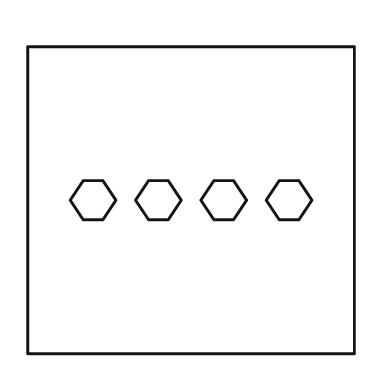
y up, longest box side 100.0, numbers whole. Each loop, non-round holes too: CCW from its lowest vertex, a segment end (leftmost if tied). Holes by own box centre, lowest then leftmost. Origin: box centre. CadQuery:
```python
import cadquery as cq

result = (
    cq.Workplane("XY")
    .moveTo(-50.0, -47.0)
    .lineTo(50.0, -47.0)
    .lineTo(50.0, 47.0)
    .lineTo(-50.0, 47.0)
    .close()
    .moveTo(-33.0, -6.0)
    .lineTo(-27.0, -6.0)
    .lineTo(-23.0, 0.0)
    .lineTo(-27.0, 6.0)
    .lineTo(-33.0, 6.0)
    .lineTo(-37.0, 0.0)
    .close()
    .moveTo(-13.0, -6.0)
    .lineTo(-7.0, -6.0)
    .lineTo(-3.0, 0.0)
    .lineTo(-7.0, 6.0)
    .lineTo(-13.0, 6.0)
    .lineTo(-17.0, 0.0)
    .close()
    .moveTo(7.0, -6.0)
    .lineTo(13.0, -6.0)
    .lineTo(17.0, 0.0)
    .lineTo(13.0, 6.0)
    .lineTo(7.0, 6.0)
    .lineTo(3.0, 0.0)
    .close()
    .moveTo(27.0, -6.0)
    .lineTo(33.0, -6.0)
    .lineTo(37.0, 0.0)
    .lineTo(33.0, 6.0)
    .lineTo(27.0, 6.0)
    .lineTo(23.0, 0.0)
    .close()
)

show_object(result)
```